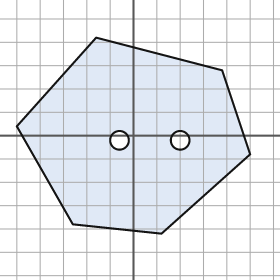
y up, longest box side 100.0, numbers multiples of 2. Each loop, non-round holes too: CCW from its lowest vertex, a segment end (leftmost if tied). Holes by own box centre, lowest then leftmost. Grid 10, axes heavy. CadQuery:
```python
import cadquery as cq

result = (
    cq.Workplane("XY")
    .moveTo(12.0, -42.0)
    .lineTo(50.0, -8.0)
    .lineTo(38.0, 28.0)
    .lineTo(-16.0, 42.0)
    .lineTo(-50.0, 4.0)
    .lineTo(-26.0, -38.0)
    .close()
    .moveTo(-6.0, -2.0)
    .circle(4.0)
    .moveTo(20.0, -2.0)
    .circle(4.0)
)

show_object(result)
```